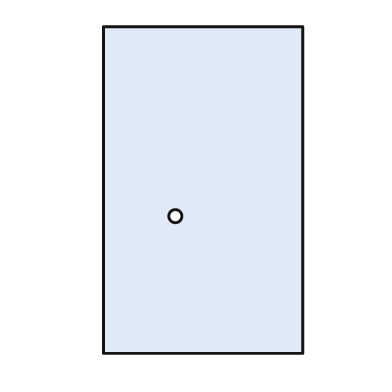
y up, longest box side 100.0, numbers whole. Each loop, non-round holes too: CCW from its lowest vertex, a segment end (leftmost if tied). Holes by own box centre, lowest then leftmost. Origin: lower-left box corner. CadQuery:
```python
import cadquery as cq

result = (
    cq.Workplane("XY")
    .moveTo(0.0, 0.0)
    .lineTo(61.0, 0.0)
    .lineTo(61.0, 100.0)
    .lineTo(0.0, 100.0)
    .close()
    .moveTo(22.0, 42.0)
    .circle(2.0)
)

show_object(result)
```